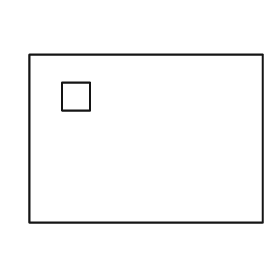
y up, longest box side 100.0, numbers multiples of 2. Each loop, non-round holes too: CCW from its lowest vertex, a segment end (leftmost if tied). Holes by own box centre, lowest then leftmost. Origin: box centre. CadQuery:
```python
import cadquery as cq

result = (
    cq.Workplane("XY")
    .moveTo(-50.0, -36.0)
    .lineTo(50.0, -36.0)
    .lineTo(50.0, 36.0)
    .lineTo(-50.0, 36.0)
    .close()
    .moveTo(-36.0, 12.0)
    .lineTo(-24.0, 12.0)
    .lineTo(-24.0, 24.0)
    .lineTo(-36.0, 24.0)
    .close()
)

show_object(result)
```